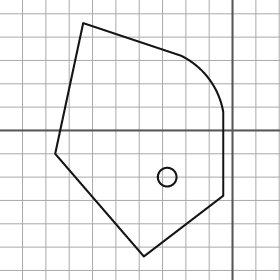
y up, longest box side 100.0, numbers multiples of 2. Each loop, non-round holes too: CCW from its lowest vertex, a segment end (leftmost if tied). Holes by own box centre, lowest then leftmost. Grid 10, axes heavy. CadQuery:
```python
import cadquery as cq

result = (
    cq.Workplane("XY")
    .moveTo(-38.0, -54.0)
    .lineTo(-4.0, -28.0)
    .lineTo(-4.0, 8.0)
    .threePointArc((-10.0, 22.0), (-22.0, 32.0))
    .lineTo(-64.0, 46.0)
    .lineTo(-76.0, -10.0)
    .close()
    .moveTo(-28.0, -20.0)
    .circle(4.0)
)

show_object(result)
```